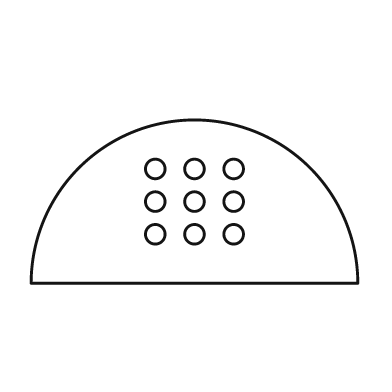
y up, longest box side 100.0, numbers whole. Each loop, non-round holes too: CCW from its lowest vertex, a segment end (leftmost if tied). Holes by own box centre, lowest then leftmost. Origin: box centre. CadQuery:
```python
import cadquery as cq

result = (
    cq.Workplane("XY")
    .moveTo(-50.0, -25.0)
    .lineTo(50.0, -25.0)
    .threePointArc((0.0, 25.0), (-50.0, -25.0))
    .close()
    .moveTo(-12.0, -10.0)
    .circle(3.0)
    .moveTo(0.0, -10.0)
    .circle(3.0)
    .moveTo(12.0, -10.0)
    .circle(3.0)
    .moveTo(-12.0, 0.0)
    .circle(3.0)
    .moveTo(0.0, 0.0)
    .circle(3.0)
    .moveTo(12.0, 0.0)
    .circle(3.0)
    .moveTo(-12.0, 10.0)
    .circle(3.0)
    .moveTo(0.0, 10.0)
    .circle(3.0)
    .moveTo(12.0, 10.0)
    .circle(3.0)
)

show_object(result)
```